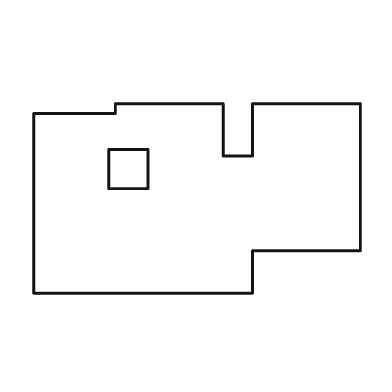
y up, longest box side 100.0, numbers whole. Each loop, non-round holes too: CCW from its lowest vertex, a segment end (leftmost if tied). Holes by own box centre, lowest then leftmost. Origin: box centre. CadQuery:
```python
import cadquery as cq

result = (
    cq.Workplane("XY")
    .moveTo(-50.0, -29.0)
    .lineTo(17.0, -29.0)
    .lineTo(17.0, -16.0)
    .lineTo(50.0, -16.0)
    .lineTo(50.0, 29.0)
    .lineTo(17.0, 29.0)
    .lineTo(17.0, 13.0)
    .lineTo(8.0, 13.0)
    .lineTo(8.0, 29.0)
    .lineTo(-25.0, 29.0)
    .lineTo(-25.0, 26.0)
    .lineTo(-50.0, 26.0)
    .close()
    .moveTo(-27.0, 3.0)
    .lineTo(-15.0, 3.0)
    .lineTo(-15.0, 15.0)
    .lineTo(-27.0, 15.0)
    .close()
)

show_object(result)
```